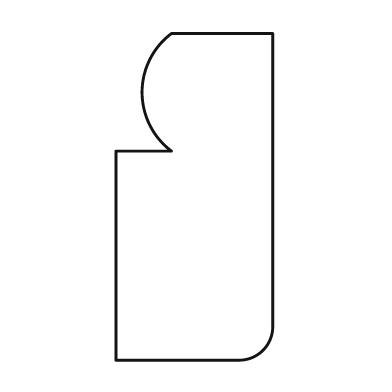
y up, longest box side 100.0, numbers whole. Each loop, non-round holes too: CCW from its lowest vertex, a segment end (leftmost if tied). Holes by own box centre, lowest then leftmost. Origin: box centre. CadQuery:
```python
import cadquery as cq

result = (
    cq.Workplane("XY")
    .moveTo(-24.0, -50.0)
    .lineTo(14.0, -50.0)
    .threePointArc((21.0, -47.0), (24.0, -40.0))
    .lineTo(24.0, 50.0)
    .lineTo(-7.0, 50.0)
    .threePointArc((-16.0, 32.0), (-7.0, 14.0))
    .lineTo(-24.0, 14.0)
    .close()
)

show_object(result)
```